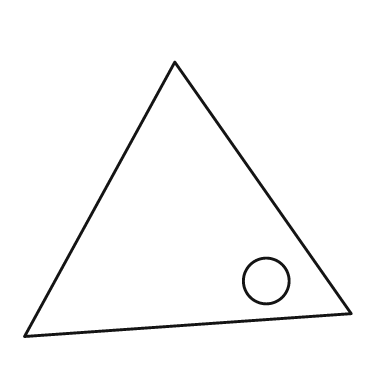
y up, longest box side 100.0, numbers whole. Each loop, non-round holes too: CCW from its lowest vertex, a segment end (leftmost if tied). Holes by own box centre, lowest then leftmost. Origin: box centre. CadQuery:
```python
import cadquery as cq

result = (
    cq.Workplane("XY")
    .moveTo(-50.0, -42.0)
    .lineTo(50.0, -35.0)
    .lineTo(-4.0, 42.0)
    .close()
    .moveTo(24.0, -25.0)
    .circle(7.0)
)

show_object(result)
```